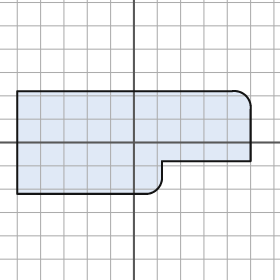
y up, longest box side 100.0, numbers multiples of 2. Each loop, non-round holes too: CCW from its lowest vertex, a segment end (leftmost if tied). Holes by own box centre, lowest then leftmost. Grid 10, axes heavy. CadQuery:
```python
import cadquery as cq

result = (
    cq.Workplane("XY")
    .moveTo(-50.0, -22.0)
    .lineTo(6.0, -22.0)
    .threePointArc((10.0, -20.0), (12.0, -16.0))
    .lineTo(12.0, -8.0)
    .lineTo(50.0, -8.0)
    .lineTo(50.0, 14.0)
    .threePointArc((48.0, 20.0), (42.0, 22.0))
    .lineTo(-50.0, 22.0)
    .close()
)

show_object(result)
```